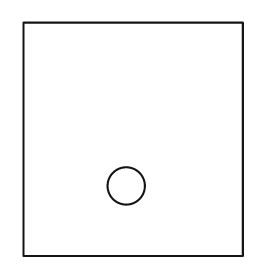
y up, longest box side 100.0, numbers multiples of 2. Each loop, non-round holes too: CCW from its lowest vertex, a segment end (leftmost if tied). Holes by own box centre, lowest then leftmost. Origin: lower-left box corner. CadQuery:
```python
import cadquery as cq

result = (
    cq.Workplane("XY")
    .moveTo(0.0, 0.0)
    .lineTo(94.0, 0.0)
    .lineTo(94.0, 100.0)
    .lineTo(0.0, 100.0)
    .close()
    .moveTo(44.0, 30.0)
    .circle(8.0)
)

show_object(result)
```